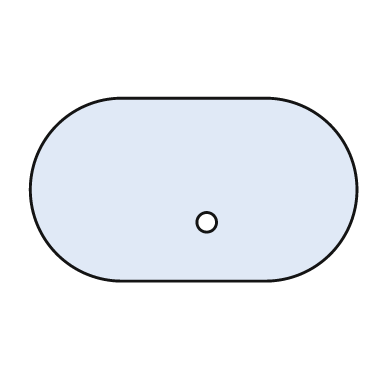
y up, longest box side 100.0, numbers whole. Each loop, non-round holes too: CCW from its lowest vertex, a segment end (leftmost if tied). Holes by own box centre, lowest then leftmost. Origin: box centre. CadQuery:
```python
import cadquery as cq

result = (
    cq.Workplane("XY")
    .moveTo(-22.0, -28.0)
    .lineTo(22.0, -28.0)
    .threePointArc((50.0, 0.0), (22.0, 28.0))
    .lineTo(-22.0, 28.0)
    .threePointArc((-50.0, 0.0), (-22.0, -28.0))
    .close()
    .moveTo(4.0, -10.0)
    .circle(3.0)
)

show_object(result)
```